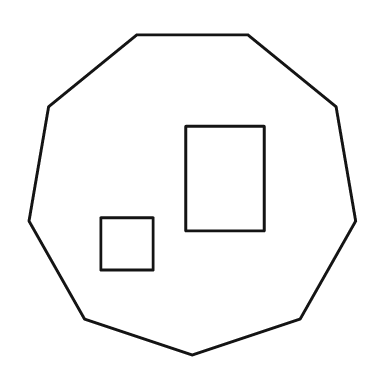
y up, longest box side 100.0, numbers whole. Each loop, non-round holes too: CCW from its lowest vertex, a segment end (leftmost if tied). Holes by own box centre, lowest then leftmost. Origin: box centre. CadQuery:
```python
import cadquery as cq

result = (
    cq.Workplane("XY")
    .moveTo(0.0, -49.0)
    .lineTo(33.0, -38.0)
    .lineTo(50.0, -8.0)
    .lineTo(44.0, 27.0)
    .lineTo(17.0, 49.0)
    .lineTo(-17.0, 49.0)
    .lineTo(-44.0, 27.0)
    .lineTo(-50.0, -8.0)
    .lineTo(-33.0, -38.0)
    .close()
    .moveTo(-28.0, -23.0)
    .lineTo(-12.0, -23.0)
    .lineTo(-12.0, -7.0)
    .lineTo(-28.0, -7.0)
    .close()
    .moveTo(-2.0, -11.0)
    .lineTo(22.0, -11.0)
    .lineTo(22.0, 21.0)
    .lineTo(-2.0, 21.0)
    .close()
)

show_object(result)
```